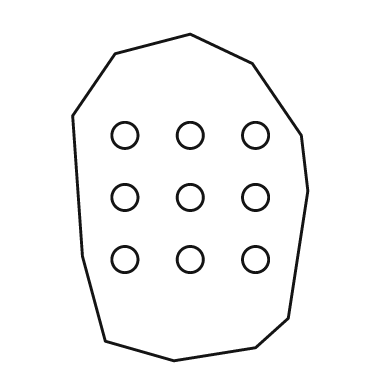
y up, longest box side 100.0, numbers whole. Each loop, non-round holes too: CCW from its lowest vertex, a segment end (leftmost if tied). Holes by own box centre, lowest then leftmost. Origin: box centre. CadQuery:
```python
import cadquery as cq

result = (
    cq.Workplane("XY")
    .moveTo(-5.0, -50.0)
    .lineTo(20.0, -46.0)
    .lineTo(30.0, -37.0)
    .lineTo(36.0, 2.0)
    .lineTo(34.0, 19.0)
    .lineTo(19.0, 41.0)
    .lineTo(0.0, 50.0)
    .lineTo(-23.0, 44.0)
    .lineTo(-36.0, 25.0)
    .lineTo(-33.0, -18.0)
    .lineTo(-26.0, -44.0)
    .close()
    .moveTo(-20.0, -19.0)
    .circle(4.0)
    .moveTo(0.0, -19.0)
    .circle(4.0)
    .moveTo(20.0, -19.0)
    .circle(4.0)
    .moveTo(-20.0, 0.0)
    .circle(4.0)
    .moveTo(0.0, 0.0)
    .circle(4.0)
    .moveTo(20.0, 0.0)
    .circle(4.0)
    .moveTo(-20.0, 19.0)
    .circle(4.0)
    .moveTo(0.0, 19.0)
    .circle(4.0)
    .moveTo(20.0, 19.0)
    .circle(4.0)
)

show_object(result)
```